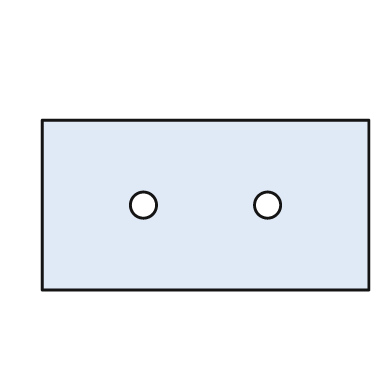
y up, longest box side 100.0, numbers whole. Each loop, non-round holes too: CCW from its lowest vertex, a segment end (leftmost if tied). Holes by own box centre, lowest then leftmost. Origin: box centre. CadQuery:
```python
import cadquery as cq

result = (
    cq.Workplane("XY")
    .moveTo(-50.0, -26.0)
    .lineTo(50.0, -26.0)
    .lineTo(50.0, 26.0)
    .lineTo(-50.0, 26.0)
    .close()
    .moveTo(-19.0, 0.0)
    .circle(4.0)
    .moveTo(19.0, 0.0)
    .circle(4.0)
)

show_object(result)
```